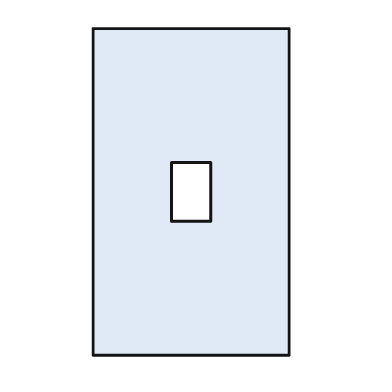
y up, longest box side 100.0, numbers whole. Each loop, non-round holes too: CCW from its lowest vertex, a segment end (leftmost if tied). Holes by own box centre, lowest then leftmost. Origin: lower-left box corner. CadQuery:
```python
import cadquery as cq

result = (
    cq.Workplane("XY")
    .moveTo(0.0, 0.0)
    .lineTo(60.0, 0.0)
    .lineTo(60.0, 100.0)
    .lineTo(0.0, 100.0)
    .close()
    .moveTo(24.0, 41.0)
    .lineTo(36.0, 41.0)
    .lineTo(36.0, 59.0)
    .lineTo(24.0, 59.0)
    .close()
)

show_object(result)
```